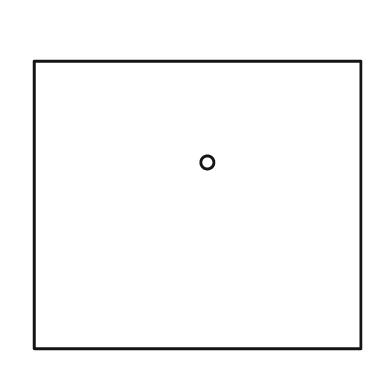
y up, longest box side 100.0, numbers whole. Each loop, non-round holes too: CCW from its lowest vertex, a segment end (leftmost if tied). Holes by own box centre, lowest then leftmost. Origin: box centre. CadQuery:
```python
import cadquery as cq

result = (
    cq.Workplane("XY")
    .moveTo(-50.0, -44.0)
    .lineTo(50.0, -44.0)
    .lineTo(50.0, 44.0)
    .lineTo(-50.0, 44.0)
    .close()
    .moveTo(3.0, 13.0)
    .circle(2.0)
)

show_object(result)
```